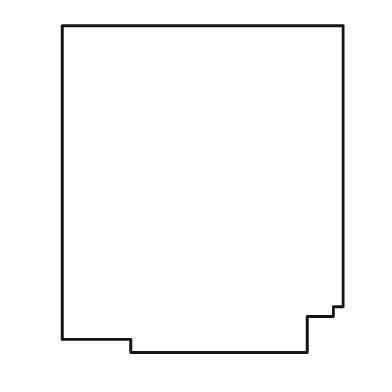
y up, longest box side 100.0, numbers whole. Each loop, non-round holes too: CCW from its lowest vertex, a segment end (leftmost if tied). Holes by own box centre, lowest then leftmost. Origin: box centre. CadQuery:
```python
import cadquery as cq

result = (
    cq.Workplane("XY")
    .moveTo(-22.0, -50.0)
    .lineTo(32.0, -50.0)
    .lineTo(32.0, -39.0)
    .lineTo(40.0, -39.0)
    .lineTo(40.0, -36.0)
    .lineTo(43.0, -36.0)
    .lineTo(43.0, 50.0)
    .lineTo(-43.0, 50.0)
    .lineTo(-43.0, -46.0)
    .lineTo(-22.0, -46.0)
    .close()
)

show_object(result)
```